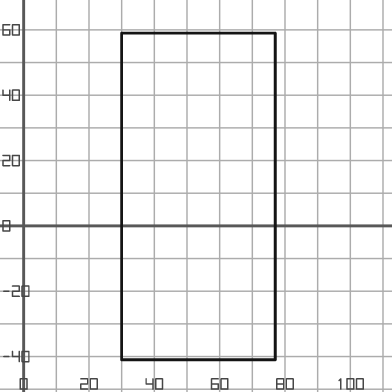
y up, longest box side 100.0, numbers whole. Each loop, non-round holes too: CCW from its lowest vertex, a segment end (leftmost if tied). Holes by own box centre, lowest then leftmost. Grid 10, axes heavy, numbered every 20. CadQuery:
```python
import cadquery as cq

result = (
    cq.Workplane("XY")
    .moveTo(30.0, -41.0)
    .lineTo(77.0, -41.0)
    .lineTo(77.0, 59.0)
    .lineTo(30.0, 59.0)
    .close()
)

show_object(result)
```